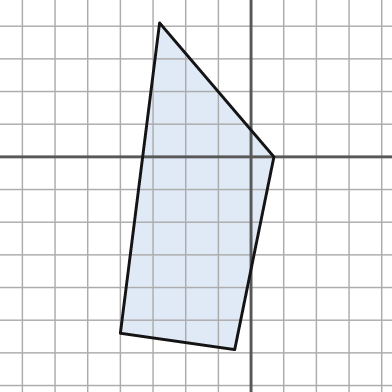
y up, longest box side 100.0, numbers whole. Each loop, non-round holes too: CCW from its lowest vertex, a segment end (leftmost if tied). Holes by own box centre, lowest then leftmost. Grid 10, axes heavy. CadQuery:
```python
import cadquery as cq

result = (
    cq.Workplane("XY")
    .moveTo(-5.0, -59.0)
    .lineTo(7.0, 0.0)
    .lineTo(-28.0, 41.0)
    .lineTo(-40.0, -54.0)
    .close()
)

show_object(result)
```